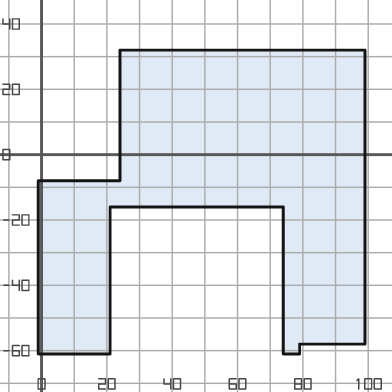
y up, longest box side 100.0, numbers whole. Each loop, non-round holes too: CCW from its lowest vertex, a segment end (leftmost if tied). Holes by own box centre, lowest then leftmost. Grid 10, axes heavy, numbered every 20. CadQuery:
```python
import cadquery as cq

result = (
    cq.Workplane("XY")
    .moveTo(-1.0, -61.0)
    .lineTo(21.0, -61.0)
    .lineTo(21.0, -16.0)
    .lineTo(74.0, -16.0)
    .lineTo(74.0, -61.0)
    .lineTo(79.0, -61.0)
    .lineTo(79.0, -58.0)
    .lineTo(99.0, -58.0)
    .lineTo(99.0, 32.0)
    .lineTo(24.0, 32.0)
    .lineTo(24.0, -8.0)
    .lineTo(-1.0, -8.0)
    .close()
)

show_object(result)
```